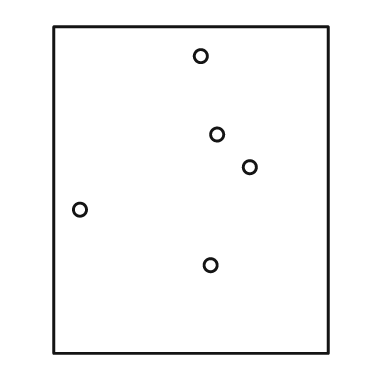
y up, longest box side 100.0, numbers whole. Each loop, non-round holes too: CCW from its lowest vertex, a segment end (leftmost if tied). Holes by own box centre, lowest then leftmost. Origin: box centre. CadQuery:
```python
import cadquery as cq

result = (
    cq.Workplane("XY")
    .moveTo(-42.0, -50.0)
    .lineTo(42.0, -50.0)
    .lineTo(42.0, 50.0)
    .lineTo(-42.0, 50.0)
    .close()
    .moveTo(6.0, -23.0)
    .circle(2.0)
    .moveTo(-34.0, -6.0)
    .circle(2.0)
    .moveTo(18.0, 7.0)
    .circle(2.0)
    .moveTo(8.0, 17.0)
    .circle(2.0)
    .moveTo(3.0, 41.0)
    .circle(2.0)
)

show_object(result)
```